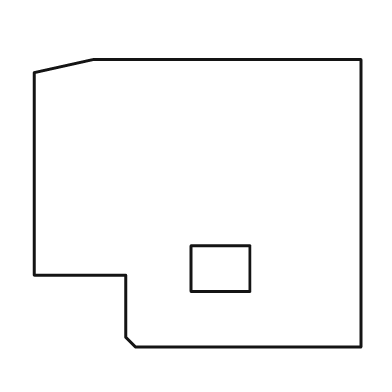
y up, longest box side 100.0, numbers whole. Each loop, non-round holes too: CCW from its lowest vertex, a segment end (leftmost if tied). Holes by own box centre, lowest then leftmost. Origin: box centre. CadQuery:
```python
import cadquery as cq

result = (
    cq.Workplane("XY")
    .moveTo(-19.0, -44.0)
    .lineTo(50.0, -44.0)
    .lineTo(50.0, 44.0)
    .lineTo(-32.0, 44.0)
    .lineTo(-50.0, 40.0)
    .lineTo(-50.0, -22.0)
    .lineTo(-22.0, -22.0)
    .lineTo(-22.0, -41.0)
    .close()
    .moveTo(-2.0, -27.0)
    .lineTo(16.0, -27.0)
    .lineTo(16.0, -13.0)
    .lineTo(-2.0, -13.0)
    .close()
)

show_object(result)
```